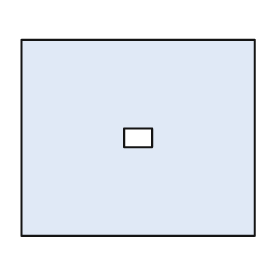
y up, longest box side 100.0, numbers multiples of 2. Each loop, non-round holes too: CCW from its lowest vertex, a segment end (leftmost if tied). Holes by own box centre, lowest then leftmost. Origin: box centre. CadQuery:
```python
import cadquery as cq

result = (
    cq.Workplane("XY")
    .moveTo(-50.0, -42.0)
    .lineTo(50.0, -42.0)
    .lineTo(50.0, 42.0)
    .lineTo(-50.0, 42.0)
    .close()
    .moveTo(-6.0, -4.0)
    .lineTo(6.0, -4.0)
    .lineTo(6.0, 4.0)
    .lineTo(-6.0, 4.0)
    .close()
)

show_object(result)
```